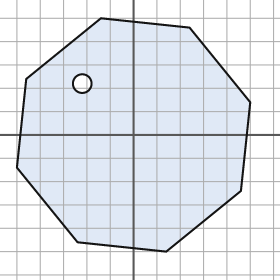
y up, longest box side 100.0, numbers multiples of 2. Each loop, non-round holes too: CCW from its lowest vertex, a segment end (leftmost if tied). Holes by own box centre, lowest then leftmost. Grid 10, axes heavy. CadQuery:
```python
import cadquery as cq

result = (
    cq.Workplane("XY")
    .moveTo(14.0, -50.0)
    .lineTo(46.0, -24.0)
    .lineTo(50.0, 14.0)
    .lineTo(24.0, 46.0)
    .lineTo(-14.0, 50.0)
    .lineTo(-46.0, 24.0)
    .lineTo(-50.0, -14.0)
    .lineTo(-24.0, -46.0)
    .close()
    .moveTo(-22.0, 22.0)
    .circle(4.0)
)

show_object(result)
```